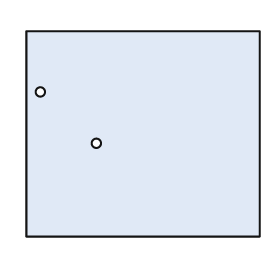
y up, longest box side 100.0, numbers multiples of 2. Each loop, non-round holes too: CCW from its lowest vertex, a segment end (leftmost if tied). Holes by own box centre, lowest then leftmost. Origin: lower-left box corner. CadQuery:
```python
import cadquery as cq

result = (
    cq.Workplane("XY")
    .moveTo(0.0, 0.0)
    .lineTo(100.0, 0.0)
    .lineTo(100.0, 88.0)
    .lineTo(0.0, 88.0)
    .close()
    .moveTo(30.0, 40.0)
    .circle(2.0)
    .moveTo(6.0, 62.0)
    .circle(2.0)
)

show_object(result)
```